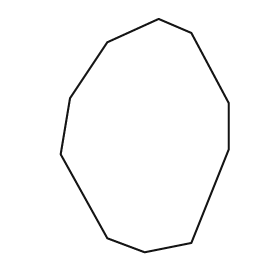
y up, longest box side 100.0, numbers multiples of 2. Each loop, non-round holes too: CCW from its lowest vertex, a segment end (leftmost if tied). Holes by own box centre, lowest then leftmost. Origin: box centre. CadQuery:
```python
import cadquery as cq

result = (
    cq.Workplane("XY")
    .moveTo(0.0, -50.0)
    .lineTo(20.0, -46.0)
    .lineTo(36.0, -6.0)
    .lineTo(36.0, 14.0)
    .lineTo(20.0, 44.0)
    .lineTo(6.0, 50.0)
    .lineTo(-16.0, 40.0)
    .lineTo(-32.0, 16.0)
    .lineTo(-36.0, -8.0)
    .lineTo(-16.0, -44.0)
    .close()
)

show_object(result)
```